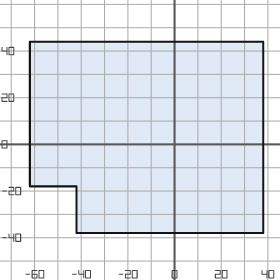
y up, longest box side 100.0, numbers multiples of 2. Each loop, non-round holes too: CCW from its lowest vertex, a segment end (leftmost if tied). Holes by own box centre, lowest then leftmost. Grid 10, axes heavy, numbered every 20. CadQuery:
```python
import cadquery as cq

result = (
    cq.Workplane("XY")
    .moveTo(-42.0, -38.0)
    .lineTo(38.0, -38.0)
    .lineTo(38.0, 44.0)
    .lineTo(-62.0, 44.0)
    .lineTo(-62.0, -18.0)
    .lineTo(-42.0, -18.0)
    .close()
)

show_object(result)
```